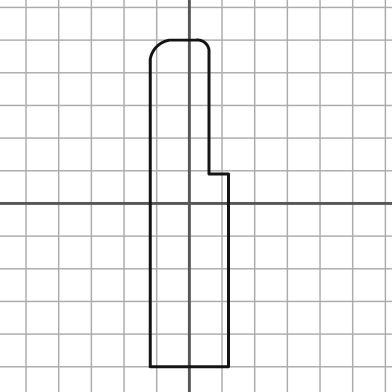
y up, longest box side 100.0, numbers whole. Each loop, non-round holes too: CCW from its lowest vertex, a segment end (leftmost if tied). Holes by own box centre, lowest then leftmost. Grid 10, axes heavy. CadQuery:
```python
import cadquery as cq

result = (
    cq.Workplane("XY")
    .moveTo(-12.0, -50.0)
    .lineTo(12.0, -50.0)
    .lineTo(12.0, 9.0)
    .lineTo(6.0, 9.0)
    .lineTo(6.0, 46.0)
    .threePointArc((5.0, 49.0), (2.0, 50.0))
    .lineTo(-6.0, 50.0)
    .threePointArc((-10.0, 48.0), (-12.0, 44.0))
    .close()
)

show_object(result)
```